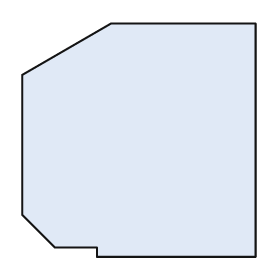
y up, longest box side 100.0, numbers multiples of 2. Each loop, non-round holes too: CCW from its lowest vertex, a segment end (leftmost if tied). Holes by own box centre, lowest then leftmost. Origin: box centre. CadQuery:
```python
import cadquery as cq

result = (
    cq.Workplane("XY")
    .moveTo(-18.0, -50.0)
    .lineTo(50.0, -50.0)
    .lineTo(50.0, 50.0)
    .lineTo(-12.0, 50.0)
    .lineTo(-50.0, 28.0)
    .lineTo(-50.0, -32.0)
    .lineTo(-36.0, -46.0)
    .lineTo(-18.0, -46.0)
    .close()
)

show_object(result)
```